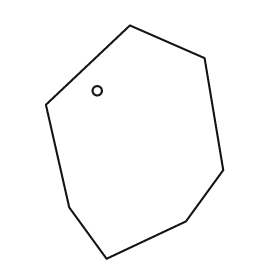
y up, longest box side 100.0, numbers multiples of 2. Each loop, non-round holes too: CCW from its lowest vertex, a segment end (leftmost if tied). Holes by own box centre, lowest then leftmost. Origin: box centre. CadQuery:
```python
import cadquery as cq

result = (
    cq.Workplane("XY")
    .moveTo(-12.0, -50.0)
    .lineTo(22.0, -34.0)
    .lineTo(38.0, -12.0)
    .lineTo(30.0, 36.0)
    .lineTo(-2.0, 50.0)
    .lineTo(-38.0, 16.0)
    .lineTo(-28.0, -28.0)
    .close()
    .moveTo(-16.0, 22.0)
    .circle(2.0)
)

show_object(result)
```